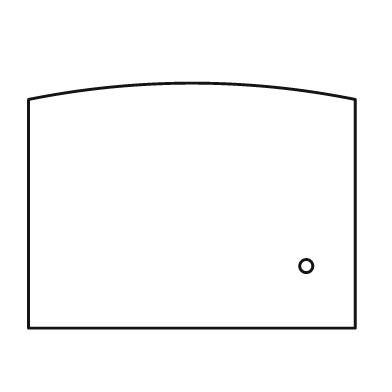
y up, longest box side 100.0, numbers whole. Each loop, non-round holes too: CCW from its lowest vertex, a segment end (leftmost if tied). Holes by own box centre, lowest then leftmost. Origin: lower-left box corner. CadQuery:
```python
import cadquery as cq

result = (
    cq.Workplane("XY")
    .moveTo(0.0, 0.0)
    .lineTo(100.0, 0.0)
    .lineTo(100.0, 70.0)
    .threePointArc((50.0, 75.0), (0.0, 70.0))
    .close()
    .moveTo(85.0, 19.0)
    .circle(2.0)
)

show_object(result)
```